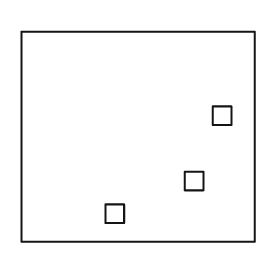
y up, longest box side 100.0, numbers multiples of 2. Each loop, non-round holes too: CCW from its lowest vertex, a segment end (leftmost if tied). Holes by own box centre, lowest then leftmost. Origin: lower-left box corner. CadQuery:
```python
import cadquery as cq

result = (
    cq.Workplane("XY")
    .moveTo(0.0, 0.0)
    .lineTo(100.0, 0.0)
    .lineTo(100.0, 90.0)
    .lineTo(0.0, 90.0)
    .close()
    .moveTo(36.0, 8.0)
    .lineTo(44.0, 8.0)
    .lineTo(44.0, 16.0)
    .lineTo(36.0, 16.0)
    .close()
    .moveTo(70.0, 22.0)
    .lineTo(78.0, 22.0)
    .lineTo(78.0, 30.0)
    .lineTo(70.0, 30.0)
    .close()
    .moveTo(82.0, 50.0)
    .lineTo(90.0, 50.0)
    .lineTo(90.0, 58.0)
    .lineTo(82.0, 58.0)
    .close()
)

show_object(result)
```